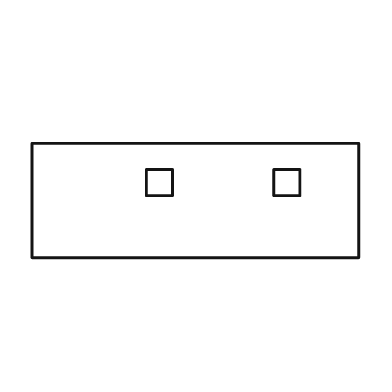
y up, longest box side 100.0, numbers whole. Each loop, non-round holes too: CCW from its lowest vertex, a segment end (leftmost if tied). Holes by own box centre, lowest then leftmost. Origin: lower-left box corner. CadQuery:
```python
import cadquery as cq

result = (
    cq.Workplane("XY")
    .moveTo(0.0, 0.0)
    .lineTo(100.0, 0.0)
    .lineTo(100.0, 35.0)
    .lineTo(0.0, 35.0)
    .close()
    .moveTo(35.0, 19.0)
    .lineTo(43.0, 19.0)
    .lineTo(43.0, 27.0)
    .lineTo(35.0, 27.0)
    .close()
    .moveTo(74.0, 19.0)
    .lineTo(82.0, 19.0)
    .lineTo(82.0, 27.0)
    .lineTo(74.0, 27.0)
    .close()
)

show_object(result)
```